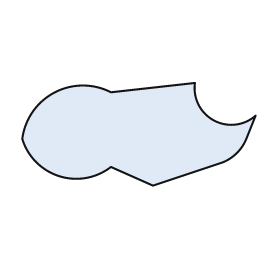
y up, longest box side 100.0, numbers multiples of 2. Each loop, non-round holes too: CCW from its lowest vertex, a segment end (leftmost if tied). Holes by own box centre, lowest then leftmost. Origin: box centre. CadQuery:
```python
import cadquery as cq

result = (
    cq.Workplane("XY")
    .moveTo(6.0, -22.0)
    .lineTo(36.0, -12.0)
    .threePointArc((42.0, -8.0), (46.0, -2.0))
    .lineTo(50.0, 8.0)
    .threePointArc((32.0, 6.0), (24.0, 22.0))
    .lineTo(-12.0, 18.0)
    .threePointArc((-36.0, 18.0), (-50.0, -2.0))
    .threePointArc((-34.0, -18.0), (-12.0, -14.0))
    .close()
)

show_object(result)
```